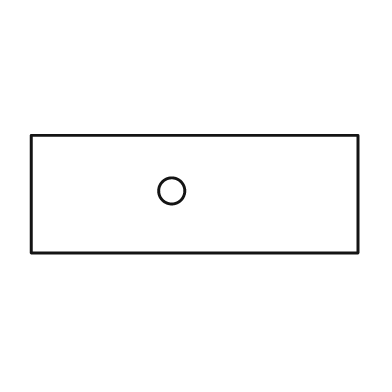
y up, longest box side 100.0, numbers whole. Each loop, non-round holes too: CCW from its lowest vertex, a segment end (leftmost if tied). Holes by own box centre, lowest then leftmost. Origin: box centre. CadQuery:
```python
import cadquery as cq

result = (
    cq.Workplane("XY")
    .moveTo(-50.0, -18.0)
    .lineTo(50.0, -18.0)
    .lineTo(50.0, 18.0)
    .lineTo(-50.0, 18.0)
    .close()
    .moveTo(-7.0, 1.0)
    .circle(4.0)
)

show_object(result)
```